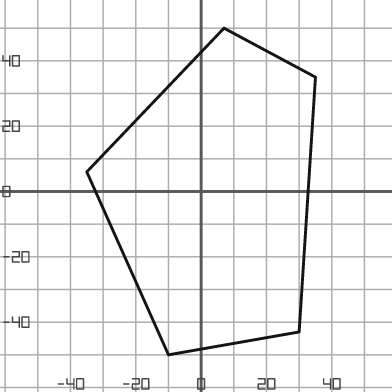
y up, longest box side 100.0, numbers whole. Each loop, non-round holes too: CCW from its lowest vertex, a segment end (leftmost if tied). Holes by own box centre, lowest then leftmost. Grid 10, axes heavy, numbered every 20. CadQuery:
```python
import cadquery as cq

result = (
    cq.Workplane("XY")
    .moveTo(-10.0, -50.0)
    .lineTo(30.0, -43.0)
    .lineTo(35.0, 35.0)
    .lineTo(7.0, 50.0)
    .lineTo(-35.0, 6.0)
    .close()
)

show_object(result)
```